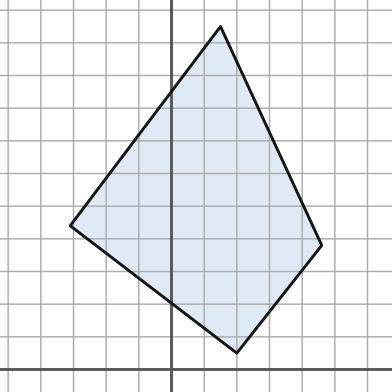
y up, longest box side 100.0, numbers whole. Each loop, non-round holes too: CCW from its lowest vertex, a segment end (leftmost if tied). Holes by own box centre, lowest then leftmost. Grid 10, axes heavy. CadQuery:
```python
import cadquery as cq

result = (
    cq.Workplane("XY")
    .moveTo(20.0, 5.0)
    .lineTo(46.0, 38.0)
    .lineTo(15.0, 105.0)
    .lineTo(-31.0, 44.0)
    .close()
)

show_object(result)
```